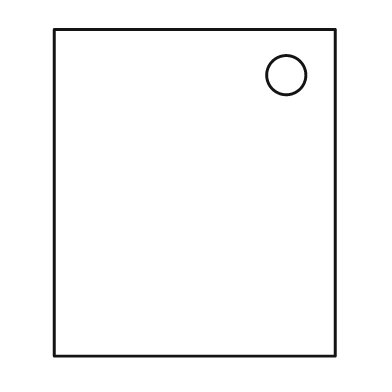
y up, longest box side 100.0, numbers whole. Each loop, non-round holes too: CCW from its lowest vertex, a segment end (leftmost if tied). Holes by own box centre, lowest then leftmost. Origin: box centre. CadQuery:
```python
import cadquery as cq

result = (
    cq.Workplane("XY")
    .moveTo(-43.0, -50.0)
    .lineTo(43.0, -50.0)
    .lineTo(43.0, 50.0)
    .lineTo(-43.0, 50.0)
    .close()
    .moveTo(28.0, 36.0)
    .circle(6.0)
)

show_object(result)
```